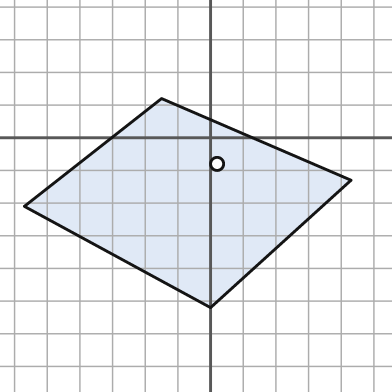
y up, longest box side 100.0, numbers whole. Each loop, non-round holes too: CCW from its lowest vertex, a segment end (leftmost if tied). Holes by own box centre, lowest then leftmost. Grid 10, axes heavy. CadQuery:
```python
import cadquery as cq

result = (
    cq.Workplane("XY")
    .moveTo(0.0, -52.0)
    .lineTo(43.0, -13.0)
    .lineTo(-15.0, 12.0)
    .lineTo(-57.0, -21.0)
    .close()
    .moveTo(2.0, -8.0)
    .circle(2.0)
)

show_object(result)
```